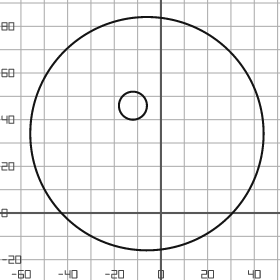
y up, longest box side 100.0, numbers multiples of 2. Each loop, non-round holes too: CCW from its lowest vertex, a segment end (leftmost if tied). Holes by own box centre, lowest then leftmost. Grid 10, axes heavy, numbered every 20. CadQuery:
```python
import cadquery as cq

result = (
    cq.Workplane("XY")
    .moveTo(-6.0, 34.0)
    .circle(50.0)
    .moveTo(-12.0, 46.0)
    .circle(6.0)
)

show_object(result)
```